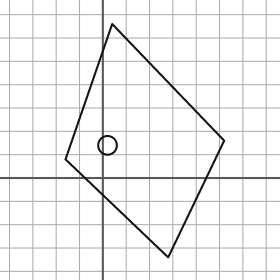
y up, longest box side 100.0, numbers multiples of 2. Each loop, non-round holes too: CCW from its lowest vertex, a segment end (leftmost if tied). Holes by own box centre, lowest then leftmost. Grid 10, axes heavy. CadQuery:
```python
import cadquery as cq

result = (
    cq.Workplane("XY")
    .moveTo(28.0, -34.0)
    .lineTo(52.0, 16.0)
    .lineTo(4.0, 66.0)
    .lineTo(-16.0, 8.0)
    .close()
    .moveTo(2.0, 14.0)
    .circle(4.0)
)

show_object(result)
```